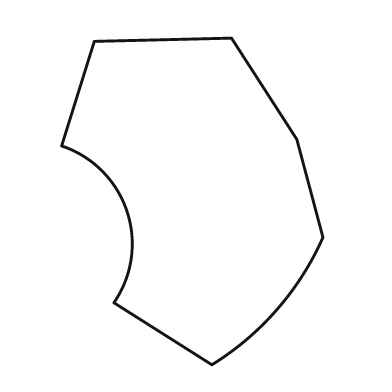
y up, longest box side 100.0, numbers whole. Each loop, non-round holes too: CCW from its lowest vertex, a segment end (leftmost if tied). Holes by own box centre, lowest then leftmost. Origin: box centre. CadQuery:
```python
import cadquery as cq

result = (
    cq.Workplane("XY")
    .moveTo(6.0, -50.0)
    .threePointArc((26.0, -33.0), (40.0, -11.0))
    .lineTo(32.0, 19.0)
    .lineTo(12.0, 50.0)
    .lineTo(-30.0, 49.0)
    .lineTo(-40.0, 17.0)
    .threePointArc((-20.0, -3.0), (-24.0, -31.0))
    .close()
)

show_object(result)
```